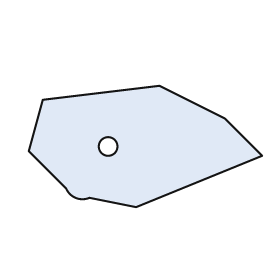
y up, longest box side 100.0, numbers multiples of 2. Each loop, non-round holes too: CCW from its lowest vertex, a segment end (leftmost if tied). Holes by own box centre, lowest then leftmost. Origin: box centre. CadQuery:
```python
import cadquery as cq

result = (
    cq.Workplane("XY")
    .moveTo(-4.0, -26.0)
    .lineTo(50.0, -4.0)
    .lineTo(34.0, 12.0)
    .lineTo(6.0, 26.0)
    .lineTo(-44.0, 20.0)
    .lineTo(-50.0, -2.0)
    .lineTo(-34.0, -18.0)
    .threePointArc((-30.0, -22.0), (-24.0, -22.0))
    .close()
    .moveTo(-16.0, 0.0)
    .circle(4.0)
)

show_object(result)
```